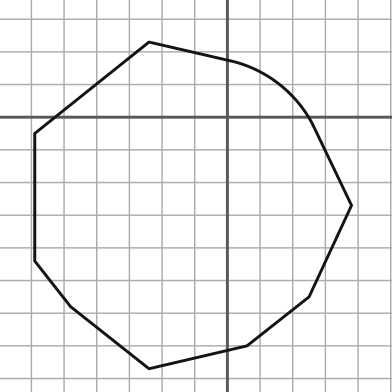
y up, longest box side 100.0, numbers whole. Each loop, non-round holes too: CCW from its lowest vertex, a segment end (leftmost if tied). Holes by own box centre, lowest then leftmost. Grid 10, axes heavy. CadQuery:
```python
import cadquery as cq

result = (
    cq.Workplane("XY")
    .moveTo(-24.0, -77.0)
    .lineTo(6.0, -70.0)
    .lineTo(25.0, -55.0)
    .lineTo(38.0, -27.0)
    .lineTo(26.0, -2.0)
    .threePointArc((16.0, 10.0), (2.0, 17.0))
    .lineTo(-24.0, 23.0)
    .lineTo(-59.0, -5.0)
    .lineTo(-59.0, -44.0)
    .lineTo(-48.0, -58.0)
    .close()
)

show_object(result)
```